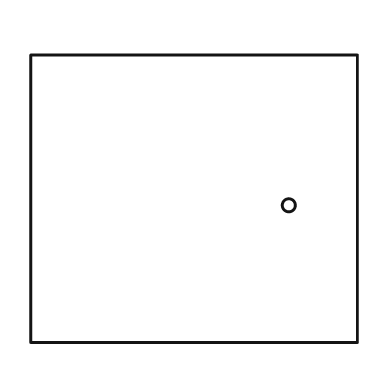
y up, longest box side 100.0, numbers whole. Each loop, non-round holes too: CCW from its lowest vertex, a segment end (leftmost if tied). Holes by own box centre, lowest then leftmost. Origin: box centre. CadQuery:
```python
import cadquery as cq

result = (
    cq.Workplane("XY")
    .moveTo(-50.0, -44.0)
    .lineTo(50.0, -44.0)
    .lineTo(50.0, 44.0)
    .lineTo(-50.0, 44.0)
    .close()
    .moveTo(29.0, -2.0)
    .circle(2.0)
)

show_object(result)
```